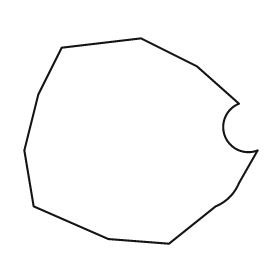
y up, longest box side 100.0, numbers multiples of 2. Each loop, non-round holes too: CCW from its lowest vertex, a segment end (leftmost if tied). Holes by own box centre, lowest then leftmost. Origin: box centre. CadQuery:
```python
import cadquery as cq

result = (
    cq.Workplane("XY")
    .moveTo(12.0, -44.0)
    .lineTo(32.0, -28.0)
    .threePointArc((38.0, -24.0), (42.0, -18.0))
    .lineTo(50.0, -4.0)
    .threePointArc((36.0, 2.0), (42.0, 16.0))
    .lineTo(24.0, 32.0)
    .lineTo(0.0, 44.0)
    .lineTo(-34.0, 40.0)
    .lineTo(-44.0, 20.0)
    .lineTo(-50.0, -4.0)
    .lineTo(-46.0, -28.0)
    .lineTo(-14.0, -42.0)
    .close()
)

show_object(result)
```